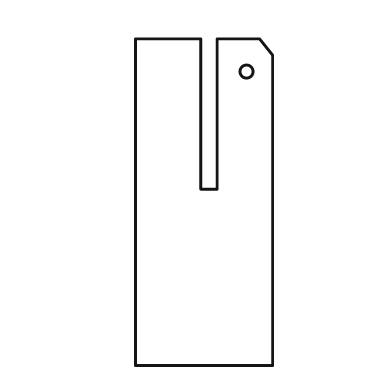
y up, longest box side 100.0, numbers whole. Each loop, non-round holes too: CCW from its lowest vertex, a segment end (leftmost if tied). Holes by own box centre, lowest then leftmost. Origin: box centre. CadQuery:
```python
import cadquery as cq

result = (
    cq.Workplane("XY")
    .moveTo(-21.0, -50.0)
    .lineTo(21.0, -50.0)
    .lineTo(21.0, 45.0)
    .lineTo(17.0, 50.0)
    .lineTo(4.0, 50.0)
    .lineTo(4.0, 4.0)
    .lineTo(-1.0, 4.0)
    .lineTo(-1.0, 50.0)
    .lineTo(-21.0, 50.0)
    .close()
    .moveTo(13.0, 40.0)
    .circle(2.0)
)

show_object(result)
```